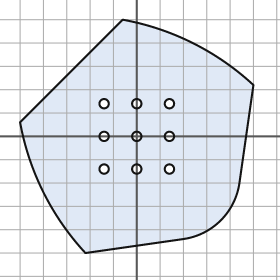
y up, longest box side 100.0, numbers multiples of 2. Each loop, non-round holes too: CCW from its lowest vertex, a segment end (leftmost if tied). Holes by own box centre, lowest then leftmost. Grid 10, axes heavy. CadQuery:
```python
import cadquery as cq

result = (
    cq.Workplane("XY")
    .moveTo(-22.0, -50.0)
    .lineTo(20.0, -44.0)
    .threePointArc((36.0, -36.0), (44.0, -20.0))
    .lineTo(50.0, 22.0)
    .threePointArc((24.0, 40.0), (-6.0, 50.0))
    .lineTo(-50.0, 6.0)
    .threePointArc((-40.0, -24.0), (-22.0, -50.0))
    .close()
    .moveTo(-14.0, -14.0)
    .circle(2.0)
    .moveTo(0.0, -14.0)
    .circle(2.0)
    .moveTo(14.0, -14.0)
    .circle(2.0)
    .moveTo(-14.0, 0.0)
    .circle(2.0)
    .moveTo(0.0, 0.0)
    .circle(2.0)
    .moveTo(14.0, 0.0)
    .circle(2.0)
    .moveTo(-14.0, 14.0)
    .circle(2.0)
    .moveTo(0.0, 14.0)
    .circle(2.0)
    .moveTo(14.0, 14.0)
    .circle(2.0)
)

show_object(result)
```